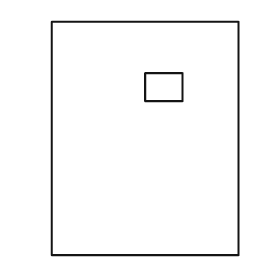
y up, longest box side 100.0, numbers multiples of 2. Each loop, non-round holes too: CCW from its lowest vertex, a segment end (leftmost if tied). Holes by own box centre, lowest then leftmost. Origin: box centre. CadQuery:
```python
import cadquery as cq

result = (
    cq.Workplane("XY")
    .moveTo(-40.0, -50.0)
    .lineTo(40.0, -50.0)
    .lineTo(40.0, 50.0)
    .lineTo(-40.0, 50.0)
    .close()
    .moveTo(0.0, 16.0)
    .lineTo(16.0, 16.0)
    .lineTo(16.0, 28.0)
    .lineTo(0.0, 28.0)
    .close()
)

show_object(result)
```